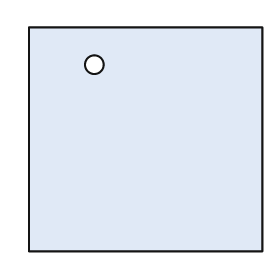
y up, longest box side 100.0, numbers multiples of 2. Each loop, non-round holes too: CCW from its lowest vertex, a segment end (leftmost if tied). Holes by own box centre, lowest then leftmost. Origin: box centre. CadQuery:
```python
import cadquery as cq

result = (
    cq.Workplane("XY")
    .moveTo(-50.0, -48.0)
    .lineTo(50.0, -48.0)
    .lineTo(50.0, 48.0)
    .lineTo(-50.0, 48.0)
    .close()
    .moveTo(-22.0, 32.0)
    .circle(4.0)
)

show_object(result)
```